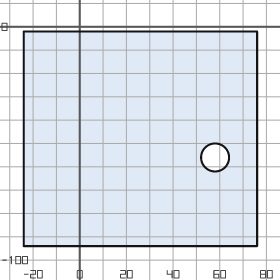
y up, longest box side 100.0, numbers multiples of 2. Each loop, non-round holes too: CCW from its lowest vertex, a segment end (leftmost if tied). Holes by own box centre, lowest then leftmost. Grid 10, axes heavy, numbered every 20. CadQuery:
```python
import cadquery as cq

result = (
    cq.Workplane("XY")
    .moveTo(-24.0, -94.0)
    .lineTo(76.0, -94.0)
    .lineTo(76.0, -2.0)
    .lineTo(-24.0, -2.0)
    .close()
    .moveTo(58.0, -56.0)
    .circle(6.0)
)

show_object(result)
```